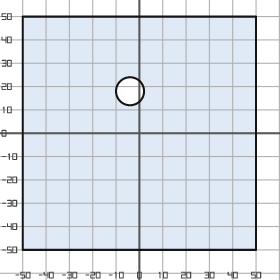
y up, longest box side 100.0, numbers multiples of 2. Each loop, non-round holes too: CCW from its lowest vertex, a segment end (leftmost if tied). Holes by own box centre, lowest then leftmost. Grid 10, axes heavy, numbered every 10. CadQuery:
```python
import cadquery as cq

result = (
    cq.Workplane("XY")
    .moveTo(-50.0, -50.0)
    .lineTo(50.0, -50.0)
    .lineTo(50.0, 50.0)
    .lineTo(-50.0, 50.0)
    .close()
    .moveTo(-4.0, 18.0)
    .circle(6.0)
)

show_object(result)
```